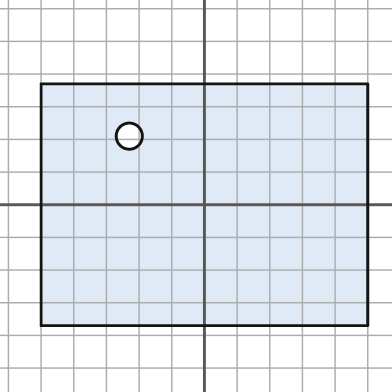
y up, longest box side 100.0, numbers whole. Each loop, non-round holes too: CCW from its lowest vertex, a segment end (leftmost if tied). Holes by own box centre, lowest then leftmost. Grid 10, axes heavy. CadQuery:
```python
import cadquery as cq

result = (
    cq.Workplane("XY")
    .moveTo(-50.0, -37.0)
    .lineTo(50.0, -37.0)
    .lineTo(50.0, 37.0)
    .lineTo(-50.0, 37.0)
    .close()
    .moveTo(-23.0, 21.0)
    .circle(4.0)
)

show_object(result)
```